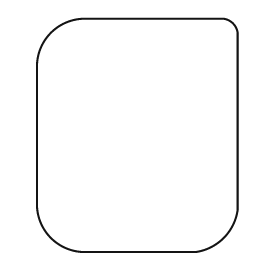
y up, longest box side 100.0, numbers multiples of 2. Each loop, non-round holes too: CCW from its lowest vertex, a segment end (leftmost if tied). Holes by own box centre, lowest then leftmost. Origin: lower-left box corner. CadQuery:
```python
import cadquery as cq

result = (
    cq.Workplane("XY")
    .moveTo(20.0, 0.0)
    .lineTo(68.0, 0.0)
    .threePointArc((80.0, 6.0), (86.0, 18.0))
    .lineTo(86.0, 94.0)
    .threePointArc((84.0, 98.0), (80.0, 100.0))
    .lineTo(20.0, 100.0)
    .threePointArc((6.0, 94.0), (0.0, 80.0))
    .lineTo(0.0, 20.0)
    .threePointArc((6.0, 6.0), (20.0, 0.0))
    .close()
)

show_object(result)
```